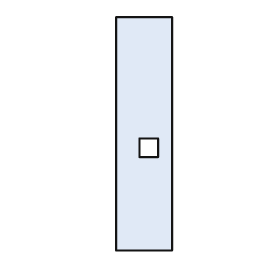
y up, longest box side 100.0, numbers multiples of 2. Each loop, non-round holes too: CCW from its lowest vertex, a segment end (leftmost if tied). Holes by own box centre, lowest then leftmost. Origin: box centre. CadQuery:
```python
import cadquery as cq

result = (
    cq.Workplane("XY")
    .moveTo(-12.0, -50.0)
    .lineTo(12.0, -50.0)
    .lineTo(12.0, 50.0)
    .lineTo(-12.0, 50.0)
    .close()
    .moveTo(-2.0, -10.0)
    .lineTo(6.0, -10.0)
    .lineTo(6.0, -2.0)
    .lineTo(-2.0, -2.0)
    .close()
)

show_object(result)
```